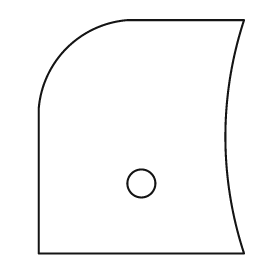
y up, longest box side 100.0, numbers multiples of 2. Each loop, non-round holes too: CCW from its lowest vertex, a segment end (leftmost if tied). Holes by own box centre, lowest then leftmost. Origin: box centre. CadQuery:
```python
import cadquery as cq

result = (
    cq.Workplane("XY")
    .moveTo(-44.0, -50.0)
    .lineTo(44.0, -50.0)
    .threePointArc((36.0, 0.0), (44.0, 50.0))
    .lineTo(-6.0, 50.0)
    .threePointArc((-32.0, 38.0), (-44.0, 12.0))
    .close()
    .moveTo(0.0, -20.0)
    .circle(6.0)
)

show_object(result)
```